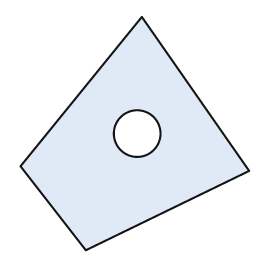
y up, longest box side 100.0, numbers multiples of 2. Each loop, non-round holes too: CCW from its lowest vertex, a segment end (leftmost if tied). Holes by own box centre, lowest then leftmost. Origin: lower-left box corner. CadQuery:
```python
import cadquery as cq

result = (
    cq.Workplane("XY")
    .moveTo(28.0, 0.0)
    .lineTo(98.0, 34.0)
    .lineTo(52.0, 100.0)
    .lineTo(0.0, 36.0)
    .close()
    .moveTo(50.0, 50.0)
    .circle(10.0)
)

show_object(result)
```